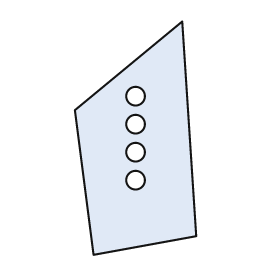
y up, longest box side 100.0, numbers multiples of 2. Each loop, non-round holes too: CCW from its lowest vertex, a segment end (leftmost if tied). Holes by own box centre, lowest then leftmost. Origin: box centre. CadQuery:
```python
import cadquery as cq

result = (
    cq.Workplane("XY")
    .moveTo(-18.0, -50.0)
    .lineTo(26.0, -42.0)
    .lineTo(20.0, 50.0)
    .lineTo(-26.0, 12.0)
    .close()
    .moveTo(0.0, -18.0)
    .circle(4.0)
    .moveTo(0.0, -6.0)
    .circle(4.0)
    .moveTo(0.0, 6.0)
    .circle(4.0)
    .moveTo(0.0, 18.0)
    .circle(4.0)
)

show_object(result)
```